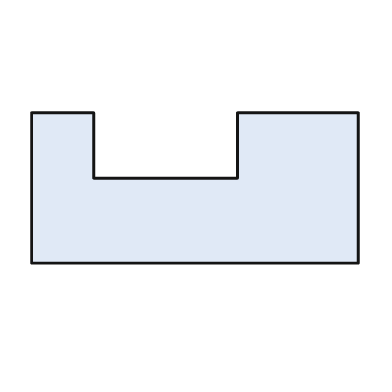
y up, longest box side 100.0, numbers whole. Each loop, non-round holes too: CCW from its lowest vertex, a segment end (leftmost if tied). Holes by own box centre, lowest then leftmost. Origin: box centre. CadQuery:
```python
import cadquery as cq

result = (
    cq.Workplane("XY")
    .moveTo(-50.0, -23.0)
    .lineTo(50.0, -23.0)
    .lineTo(50.0, 23.0)
    .lineTo(13.0, 23.0)
    .lineTo(13.0, 3.0)
    .lineTo(-31.0, 3.0)
    .lineTo(-31.0, 23.0)
    .lineTo(-50.0, 23.0)
    .close()
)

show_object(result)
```